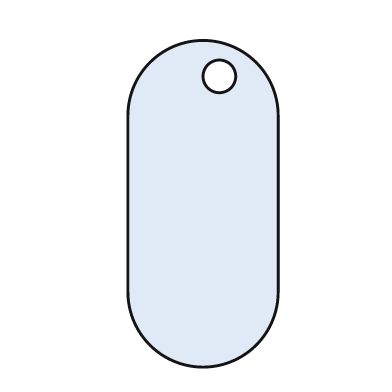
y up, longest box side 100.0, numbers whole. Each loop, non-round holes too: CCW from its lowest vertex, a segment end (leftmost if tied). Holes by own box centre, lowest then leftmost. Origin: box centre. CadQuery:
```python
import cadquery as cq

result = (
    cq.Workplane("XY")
    .moveTo(-23.0, -27.0)
    .threePointArc((0.0, -50.0), (23.0, -27.0))
    .lineTo(23.0, 27.0)
    .threePointArc((0.0, 50.0), (-23.0, 27.0))
    .close()
    .moveTo(5.0, 39.0)
    .circle(5.0)
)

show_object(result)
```